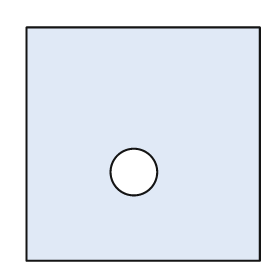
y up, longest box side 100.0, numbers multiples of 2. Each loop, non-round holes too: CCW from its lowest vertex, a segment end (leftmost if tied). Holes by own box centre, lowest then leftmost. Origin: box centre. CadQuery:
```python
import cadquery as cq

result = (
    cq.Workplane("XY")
    .moveTo(-50.0, -50.0)
    .lineTo(50.0, -50.0)
    .lineTo(50.0, 50.0)
    .lineTo(-50.0, 50.0)
    .close()
    .moveTo(-4.0, -12.0)
    .circle(10.0)
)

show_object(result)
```